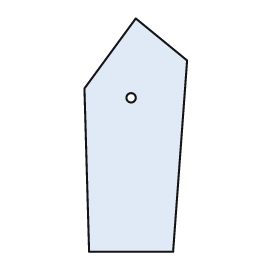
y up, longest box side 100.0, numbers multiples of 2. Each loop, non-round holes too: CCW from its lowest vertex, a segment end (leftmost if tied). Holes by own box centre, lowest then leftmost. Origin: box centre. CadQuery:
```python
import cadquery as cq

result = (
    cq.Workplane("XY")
    .moveTo(-20.0, -50.0)
    .lineTo(16.0, -50.0)
    .lineTo(22.0, 32.0)
    .lineTo(0.0, 50.0)
    .lineTo(-22.0, 20.0)
    .close()
    .moveTo(-2.0, 16.0)
    .circle(2.0)
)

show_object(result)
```